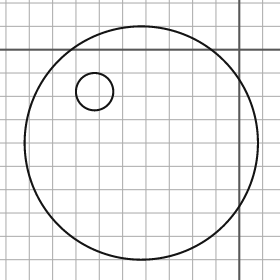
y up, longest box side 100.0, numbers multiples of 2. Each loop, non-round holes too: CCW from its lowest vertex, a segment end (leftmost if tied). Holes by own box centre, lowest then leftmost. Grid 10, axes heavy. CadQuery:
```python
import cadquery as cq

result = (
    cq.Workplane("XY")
    .moveTo(-42.0, -40.0)
    .circle(50.0)
    .moveTo(-62.0, -18.0)
    .circle(8.0)
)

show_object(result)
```